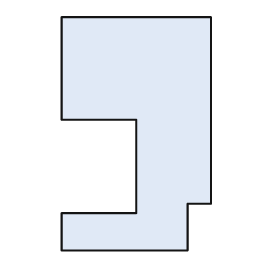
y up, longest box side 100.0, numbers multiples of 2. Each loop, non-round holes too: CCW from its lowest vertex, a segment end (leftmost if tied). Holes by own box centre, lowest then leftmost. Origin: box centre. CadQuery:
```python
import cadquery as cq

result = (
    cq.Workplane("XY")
    .moveTo(-32.0, -50.0)
    .lineTo(22.0, -50.0)
    .lineTo(22.0, -30.0)
    .lineTo(32.0, -30.0)
    .lineTo(32.0, 50.0)
    .lineTo(-32.0, 50.0)
    .lineTo(-32.0, 6.0)
    .lineTo(0.0, 6.0)
    .lineTo(0.0, -34.0)
    .lineTo(-32.0, -34.0)
    .close()
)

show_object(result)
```